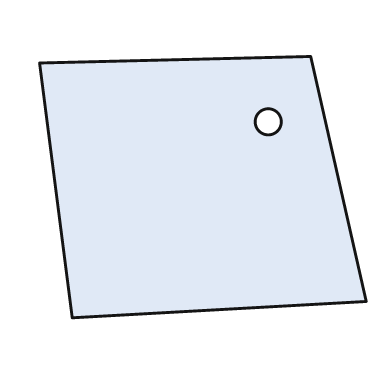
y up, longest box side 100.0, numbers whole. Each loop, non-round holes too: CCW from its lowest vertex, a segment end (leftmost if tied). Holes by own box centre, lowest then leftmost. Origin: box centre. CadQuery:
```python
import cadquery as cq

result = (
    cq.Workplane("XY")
    .moveTo(-40.0, -40.0)
    .lineTo(50.0, -35.0)
    .lineTo(33.0, 40.0)
    .lineTo(-50.0, 38.0)
    .close()
    .moveTo(20.0, 20.0)
    .circle(4.0)
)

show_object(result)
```